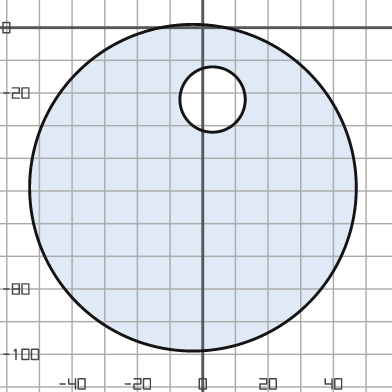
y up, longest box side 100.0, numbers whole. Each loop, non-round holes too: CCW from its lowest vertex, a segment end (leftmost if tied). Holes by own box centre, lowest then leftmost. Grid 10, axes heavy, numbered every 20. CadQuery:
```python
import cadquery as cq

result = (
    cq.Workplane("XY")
    .moveTo(-3.0, -49.0)
    .circle(50.0)
    .moveTo(3.0, -22.0)
    .circle(10.0)
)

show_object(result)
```